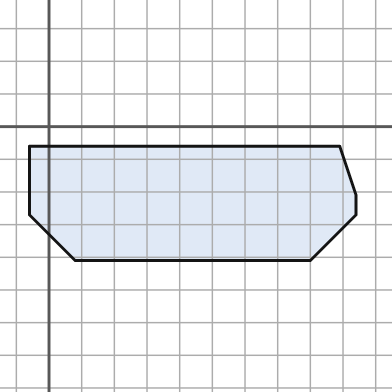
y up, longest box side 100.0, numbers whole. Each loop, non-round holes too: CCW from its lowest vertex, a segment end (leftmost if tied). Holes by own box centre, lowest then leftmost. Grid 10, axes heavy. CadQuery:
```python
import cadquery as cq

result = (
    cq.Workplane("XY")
    .moveTo(8.0, -41.0)
    .lineTo(80.0, -41.0)
    .lineTo(94.0, -27.0)
    .lineTo(94.0, -21.0)
    .lineTo(89.0, -6.0)
    .lineTo(-6.0, -6.0)
    .lineTo(-6.0, -27.0)
    .close()
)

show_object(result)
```